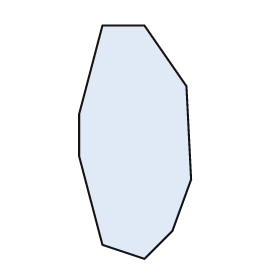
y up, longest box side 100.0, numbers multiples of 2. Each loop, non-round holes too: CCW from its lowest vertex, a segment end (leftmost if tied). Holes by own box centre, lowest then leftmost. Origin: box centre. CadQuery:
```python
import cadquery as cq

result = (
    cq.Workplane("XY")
    .moveTo(4.0, -50.0)
    .lineTo(16.0, -38.0)
    .lineTo(24.0, -16.0)
    .lineTo(22.0, 24.0)
    .lineTo(4.0, 50.0)
    .lineTo(-14.0, 50.0)
    .lineTo(-24.0, 12.0)
    .lineTo(-24.0, -6.0)
    .lineTo(-14.0, -44.0)
    .close()
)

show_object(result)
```